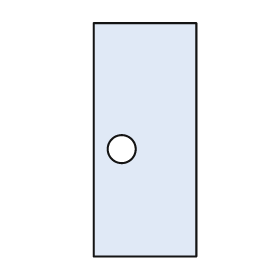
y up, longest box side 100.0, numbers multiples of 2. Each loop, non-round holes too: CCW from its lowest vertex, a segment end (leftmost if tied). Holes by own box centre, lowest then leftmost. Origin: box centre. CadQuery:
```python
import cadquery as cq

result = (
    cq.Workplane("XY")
    .moveTo(-22.0, -50.0)
    .lineTo(22.0, -50.0)
    .lineTo(22.0, 50.0)
    .lineTo(-22.0, 50.0)
    .close()
    .moveTo(-10.0, -4.0)
    .circle(6.0)
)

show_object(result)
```